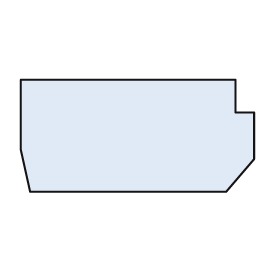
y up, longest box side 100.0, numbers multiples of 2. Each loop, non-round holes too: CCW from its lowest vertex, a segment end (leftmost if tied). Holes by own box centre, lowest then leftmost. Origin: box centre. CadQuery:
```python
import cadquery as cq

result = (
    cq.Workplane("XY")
    .moveTo(-46.0, -24.0)
    .lineTo(38.0, -24.0)
    .lineTo(50.0, -10.0)
    .lineTo(50.0, 10.0)
    .lineTo(42.0, 10.0)
    .lineTo(42.0, 24.0)
    .lineTo(-50.0, 24.0)
    .lineTo(-50.0, -6.0)
    .close()
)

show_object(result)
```